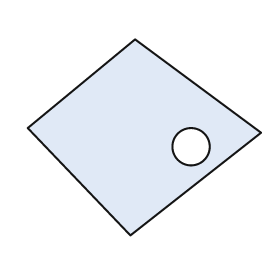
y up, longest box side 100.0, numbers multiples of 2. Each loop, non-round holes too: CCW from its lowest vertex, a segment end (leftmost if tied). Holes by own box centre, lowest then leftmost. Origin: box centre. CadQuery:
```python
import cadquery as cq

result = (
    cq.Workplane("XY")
    .moveTo(-6.0, -42.0)
    .lineTo(50.0, 2.0)
    .lineTo(-4.0, 42.0)
    .lineTo(-50.0, 4.0)
    .close()
    .moveTo(20.0, -4.0)
    .circle(8.0)
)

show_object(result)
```